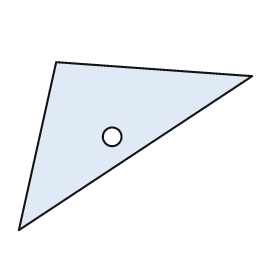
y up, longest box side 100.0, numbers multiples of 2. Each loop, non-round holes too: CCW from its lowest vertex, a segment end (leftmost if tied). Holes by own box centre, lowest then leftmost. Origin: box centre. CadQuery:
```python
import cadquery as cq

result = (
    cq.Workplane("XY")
    .moveTo(-50.0, -36.0)
    .lineTo(50.0, 30.0)
    .lineTo(-34.0, 36.0)
    .close()
    .moveTo(-10.0, 4.0)
    .circle(4.0)
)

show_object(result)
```